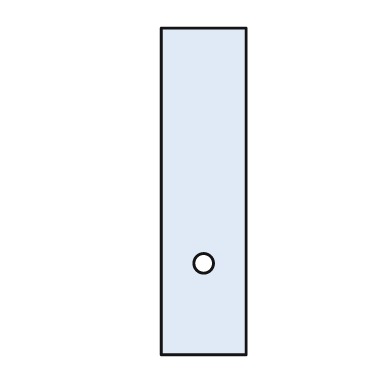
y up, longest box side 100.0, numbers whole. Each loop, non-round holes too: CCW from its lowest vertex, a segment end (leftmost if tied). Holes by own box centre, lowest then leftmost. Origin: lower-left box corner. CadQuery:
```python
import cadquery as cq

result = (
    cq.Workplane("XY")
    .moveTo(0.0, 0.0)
    .lineTo(26.0, 0.0)
    .lineTo(26.0, 100.0)
    .lineTo(0.0, 100.0)
    .close()
    .moveTo(13.0, 28.0)
    .circle(3.0)
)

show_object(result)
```